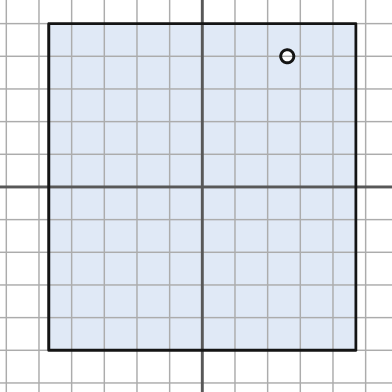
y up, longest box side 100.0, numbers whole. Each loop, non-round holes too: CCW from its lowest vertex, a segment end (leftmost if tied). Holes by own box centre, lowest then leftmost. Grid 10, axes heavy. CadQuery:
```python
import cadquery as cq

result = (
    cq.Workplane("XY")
    .moveTo(-47.0, -50.0)
    .lineTo(47.0, -50.0)
    .lineTo(47.0, 50.0)
    .lineTo(-47.0, 50.0)
    .close()
    .moveTo(26.0, 40.0)
    .circle(2.0)
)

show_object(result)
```